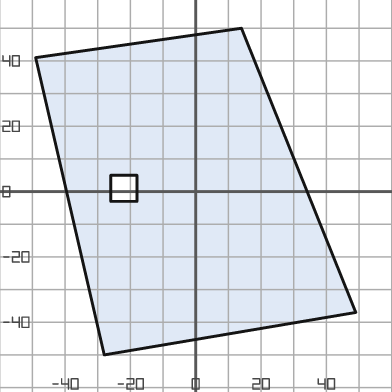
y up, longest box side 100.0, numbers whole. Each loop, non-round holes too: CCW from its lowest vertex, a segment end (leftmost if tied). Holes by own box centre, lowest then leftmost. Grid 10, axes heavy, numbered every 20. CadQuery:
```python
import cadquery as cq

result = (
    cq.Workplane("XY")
    .moveTo(-28.0, -50.0)
    .lineTo(49.0, -37.0)
    .lineTo(14.0, 50.0)
    .lineTo(-49.0, 41.0)
    .close()
    .moveTo(-26.0, -3.0)
    .lineTo(-18.0, -3.0)
    .lineTo(-18.0, 5.0)
    .lineTo(-26.0, 5.0)
    .close()
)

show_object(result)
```